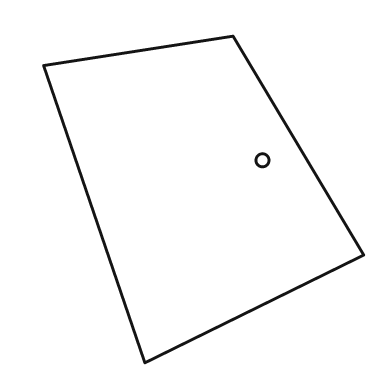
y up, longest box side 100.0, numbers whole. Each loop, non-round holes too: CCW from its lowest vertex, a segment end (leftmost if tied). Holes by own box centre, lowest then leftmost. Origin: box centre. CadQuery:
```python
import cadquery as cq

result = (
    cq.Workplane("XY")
    .moveTo(-18.0, -50.0)
    .lineTo(49.0, -17.0)
    .lineTo(9.0, 50.0)
    .lineTo(-49.0, 41.0)
    .close()
    .moveTo(18.0, 12.0)
    .circle(2.0)
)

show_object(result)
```